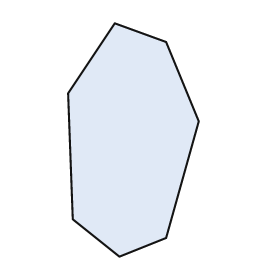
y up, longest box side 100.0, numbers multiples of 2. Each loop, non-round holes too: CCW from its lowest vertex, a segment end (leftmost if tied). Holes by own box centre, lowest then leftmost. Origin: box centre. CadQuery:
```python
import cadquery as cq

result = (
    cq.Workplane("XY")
    .moveTo(-6.0, -50.0)
    .lineTo(14.0, -42.0)
    .lineTo(28.0, 8.0)
    .lineTo(14.0, 42.0)
    .lineTo(-8.0, 50.0)
    .lineTo(-28.0, 20.0)
    .lineTo(-26.0, -34.0)
    .close()
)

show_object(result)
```